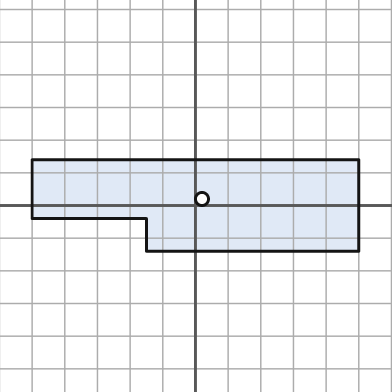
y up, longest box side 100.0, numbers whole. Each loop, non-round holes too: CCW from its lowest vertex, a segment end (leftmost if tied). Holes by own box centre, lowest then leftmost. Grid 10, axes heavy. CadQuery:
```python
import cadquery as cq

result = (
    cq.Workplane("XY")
    .moveTo(-15.0, -14.0)
    .lineTo(50.0, -14.0)
    .lineTo(50.0, 14.0)
    .lineTo(-50.0, 14.0)
    .lineTo(-50.0, -4.0)
    .lineTo(-15.0, -4.0)
    .close()
    .moveTo(2.0, 2.0)
    .circle(2.0)
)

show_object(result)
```